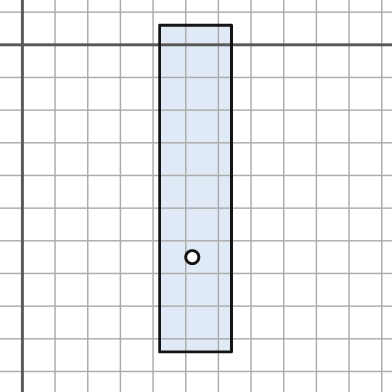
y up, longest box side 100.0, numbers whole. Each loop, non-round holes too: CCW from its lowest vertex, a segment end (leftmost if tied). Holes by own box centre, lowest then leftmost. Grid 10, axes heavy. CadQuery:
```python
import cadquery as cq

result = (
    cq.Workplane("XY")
    .moveTo(42.0, -94.0)
    .lineTo(64.0, -94.0)
    .lineTo(64.0, 6.0)
    .lineTo(42.0, 6.0)
    .close()
    .moveTo(52.0, -65.0)
    .circle(2.0)
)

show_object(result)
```